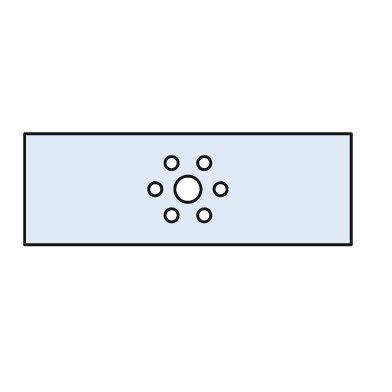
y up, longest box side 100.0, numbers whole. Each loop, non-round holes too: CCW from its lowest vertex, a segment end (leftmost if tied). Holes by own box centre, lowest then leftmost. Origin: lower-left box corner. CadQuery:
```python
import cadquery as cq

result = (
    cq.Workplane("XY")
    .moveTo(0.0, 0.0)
    .lineTo(100.0, 0.0)
    .lineTo(100.0, 34.0)
    .lineTo(0.0, 34.0)
    .close()
    .moveTo(45.0, 9.0)
    .circle(2.0)
    .moveTo(55.0, 9.0)
    .circle(2.0)
    .moveTo(40.0, 17.0)
    .circle(2.0)
    .moveTo(50.0, 17.0)
    .circle(4.0)
    .moveTo(60.0, 17.0)
    .circle(2.0)
    .moveTo(45.0, 25.0)
    .circle(2.0)
    .moveTo(55.0, 25.0)
    .circle(2.0)
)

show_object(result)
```